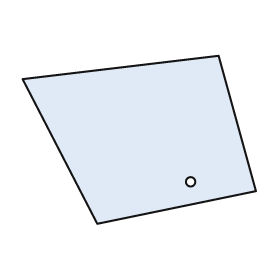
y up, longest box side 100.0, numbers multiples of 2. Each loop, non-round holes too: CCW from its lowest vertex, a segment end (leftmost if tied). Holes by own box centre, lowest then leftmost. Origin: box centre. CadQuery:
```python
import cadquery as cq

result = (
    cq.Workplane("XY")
    .moveTo(-18.0, -36.0)
    .lineTo(50.0, -22.0)
    .lineTo(34.0, 36.0)
    .lineTo(-50.0, 26.0)
    .close()
    .moveTo(22.0, -18.0)
    .circle(2.0)
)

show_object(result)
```